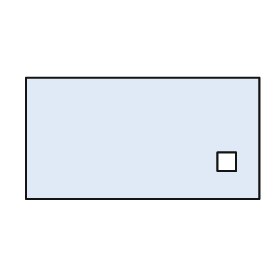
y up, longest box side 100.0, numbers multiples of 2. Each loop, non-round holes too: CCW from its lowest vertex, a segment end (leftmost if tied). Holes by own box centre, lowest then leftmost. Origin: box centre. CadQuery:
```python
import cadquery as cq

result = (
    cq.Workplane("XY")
    .moveTo(-50.0, -26.0)
    .lineTo(50.0, -26.0)
    .lineTo(50.0, 26.0)
    .lineTo(-50.0, 26.0)
    .close()
    .moveTo(32.0, -14.0)
    .lineTo(40.0, -14.0)
    .lineTo(40.0, -6.0)
    .lineTo(32.0, -6.0)
    .close()
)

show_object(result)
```